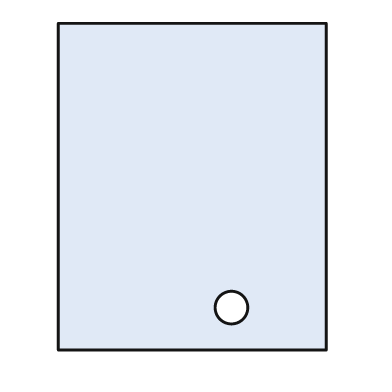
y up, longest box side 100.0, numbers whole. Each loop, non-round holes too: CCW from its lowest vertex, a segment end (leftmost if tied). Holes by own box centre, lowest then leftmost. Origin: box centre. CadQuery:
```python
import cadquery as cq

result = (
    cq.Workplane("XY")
    .moveTo(-41.0, -50.0)
    .lineTo(41.0, -50.0)
    .lineTo(41.0, 50.0)
    .lineTo(-41.0, 50.0)
    .close()
    .moveTo(12.0, -37.0)
    .circle(5.0)
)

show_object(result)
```